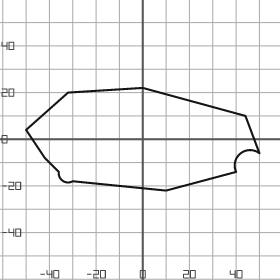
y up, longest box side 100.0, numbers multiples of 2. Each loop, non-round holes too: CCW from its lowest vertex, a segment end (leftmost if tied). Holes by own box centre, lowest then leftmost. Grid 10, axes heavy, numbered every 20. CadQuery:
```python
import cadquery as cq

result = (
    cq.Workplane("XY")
    .moveTo(10.0, -22.0)
    .lineTo(40.0, -14.0)
    .threePointArc((42.0, -6.0), (50.0, -6.0))
    .lineTo(44.0, 10.0)
    .lineTo(0.0, 22.0)
    .lineTo(-32.0, 20.0)
    .lineTo(-50.0, 4.0)
    .lineTo(-42.0, -8.0)
    .lineTo(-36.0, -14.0)
    .threePointArc((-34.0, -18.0), (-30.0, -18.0))
    .close()
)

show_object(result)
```